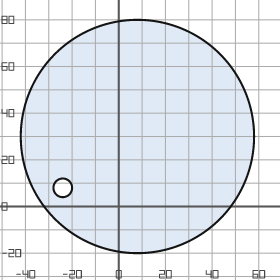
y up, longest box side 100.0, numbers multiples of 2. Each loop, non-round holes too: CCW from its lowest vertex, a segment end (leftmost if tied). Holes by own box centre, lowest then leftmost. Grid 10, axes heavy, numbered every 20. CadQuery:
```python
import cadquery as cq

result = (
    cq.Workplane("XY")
    .moveTo(8.0, 30.0)
    .circle(50.0)
    .moveTo(-24.0, 8.0)
    .circle(4.0)
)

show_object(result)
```